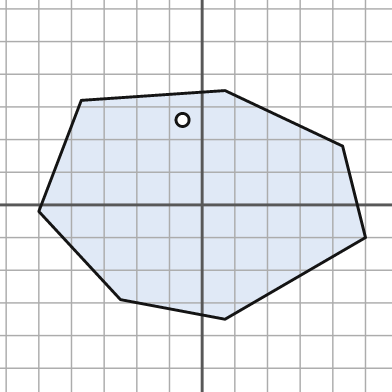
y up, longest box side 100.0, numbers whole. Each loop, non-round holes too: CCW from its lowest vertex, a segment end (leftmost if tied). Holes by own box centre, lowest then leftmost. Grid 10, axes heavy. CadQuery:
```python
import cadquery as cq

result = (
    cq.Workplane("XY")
    .moveTo(7.0, -35.0)
    .lineTo(50.0, -10.0)
    .lineTo(43.0, 18.0)
    .lineTo(7.0, 35.0)
    .lineTo(-37.0, 32.0)
    .lineTo(-50.0, -2.0)
    .lineTo(-25.0, -29.0)
    .close()
    .moveTo(-6.0, 26.0)
    .circle(2.0)
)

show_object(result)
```